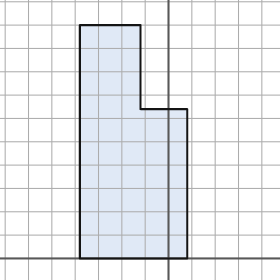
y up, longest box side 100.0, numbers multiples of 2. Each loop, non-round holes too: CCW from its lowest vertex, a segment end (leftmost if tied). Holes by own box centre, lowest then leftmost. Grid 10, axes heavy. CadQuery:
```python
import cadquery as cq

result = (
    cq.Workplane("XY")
    .moveTo(-38.0, 0.0)
    .lineTo(8.0, 0.0)
    .lineTo(8.0, 64.0)
    .lineTo(-12.0, 64.0)
    .lineTo(-12.0, 100.0)
    .lineTo(-38.0, 100.0)
    .close()
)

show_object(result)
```